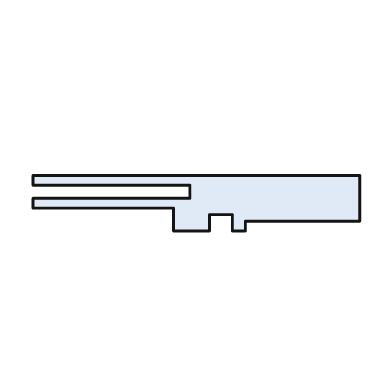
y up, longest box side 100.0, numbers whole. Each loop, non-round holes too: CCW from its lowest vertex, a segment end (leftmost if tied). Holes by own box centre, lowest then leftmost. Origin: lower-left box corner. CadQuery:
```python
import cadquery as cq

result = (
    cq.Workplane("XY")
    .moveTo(43.0, 0.0)
    .lineTo(54.0, 0.0)
    .lineTo(54.0, 5.0)
    .lineTo(61.0, 5.0)
    .lineTo(61.0, 0.0)
    .lineTo(65.0, 0.0)
    .lineTo(65.0, 3.0)
    .lineTo(100.0, 3.0)
    .lineTo(100.0, 17.0)
    .lineTo(0.0, 17.0)
    .lineTo(0.0, 14.0)
    .lineTo(48.0, 14.0)
    .lineTo(48.0, 10.0)
    .lineTo(0.0, 10.0)
    .lineTo(0.0, 7.0)
    .lineTo(43.0, 7.0)
    .close()
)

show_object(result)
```